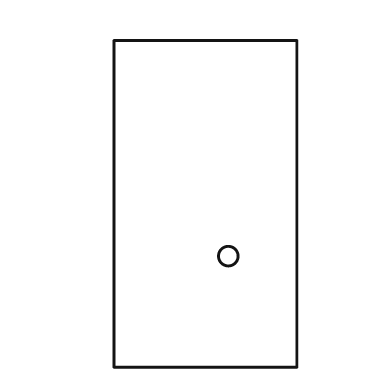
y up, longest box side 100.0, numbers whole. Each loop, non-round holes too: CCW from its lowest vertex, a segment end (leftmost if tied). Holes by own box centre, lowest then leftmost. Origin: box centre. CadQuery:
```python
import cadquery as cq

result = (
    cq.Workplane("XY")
    .moveTo(-28.0, -50.0)
    .lineTo(28.0, -50.0)
    .lineTo(28.0, 50.0)
    .lineTo(-28.0, 50.0)
    .close()
    .moveTo(7.0, -16.0)
    .circle(3.0)
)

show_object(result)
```